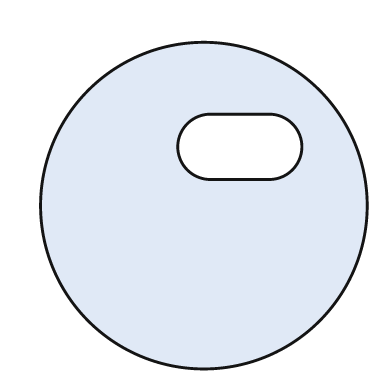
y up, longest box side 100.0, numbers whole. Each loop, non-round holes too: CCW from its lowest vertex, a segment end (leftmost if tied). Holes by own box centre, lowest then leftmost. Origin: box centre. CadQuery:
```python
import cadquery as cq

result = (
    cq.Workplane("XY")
    .moveTo(0.0, 0.0)
    .circle(50.0)
    .moveTo(2.0, 8.0)
    .lineTo(20.0, 8.0)
    .threePointArc((30.0, 18.0), (20.0, 28.0))
    .lineTo(2.0, 28.0)
    .threePointArc((-8.0, 18.0), (2.0, 8.0))
    .close()
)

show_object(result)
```